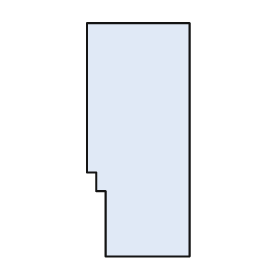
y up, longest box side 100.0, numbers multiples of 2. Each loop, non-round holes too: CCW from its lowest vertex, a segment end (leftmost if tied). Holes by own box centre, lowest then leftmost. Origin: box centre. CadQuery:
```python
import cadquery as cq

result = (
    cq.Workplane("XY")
    .moveTo(-14.0, -50.0)
    .lineTo(22.0, -50.0)
    .lineTo(22.0, 50.0)
    .lineTo(-22.0, 50.0)
    .lineTo(-22.0, -14.0)
    .lineTo(-18.0, -14.0)
    .lineTo(-18.0, -22.0)
    .lineTo(-14.0, -22.0)
    .close()
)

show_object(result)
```